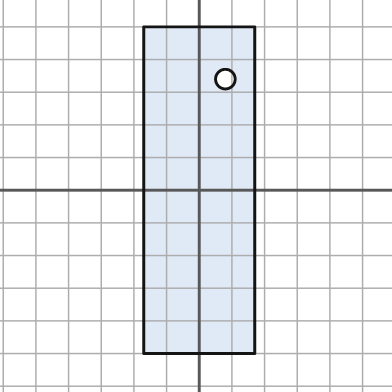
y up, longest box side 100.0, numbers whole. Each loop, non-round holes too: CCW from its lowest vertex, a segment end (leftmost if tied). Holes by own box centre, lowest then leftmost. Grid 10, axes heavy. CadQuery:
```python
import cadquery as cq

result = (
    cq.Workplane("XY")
    .moveTo(-17.0, -50.0)
    .lineTo(17.0, -50.0)
    .lineTo(17.0, 50.0)
    .lineTo(-17.0, 50.0)
    .close()
    .moveTo(8.0, 34.0)
    .circle(3.0)
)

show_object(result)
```